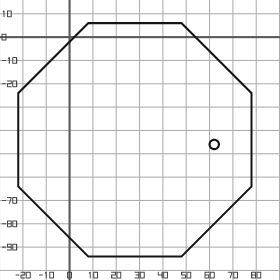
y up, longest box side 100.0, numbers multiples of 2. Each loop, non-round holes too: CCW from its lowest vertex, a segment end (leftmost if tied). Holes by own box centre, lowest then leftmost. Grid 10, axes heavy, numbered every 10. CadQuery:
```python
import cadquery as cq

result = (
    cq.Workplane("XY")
    .moveTo(8.0, -94.0)
    .lineTo(48.0, -94.0)
    .lineTo(78.0, -64.0)
    .lineTo(78.0, -24.0)
    .lineTo(48.0, 6.0)
    .lineTo(8.0, 6.0)
    .lineTo(-22.0, -24.0)
    .lineTo(-22.0, -64.0)
    .close()
    .moveTo(62.0, -46.0)
    .circle(2.0)
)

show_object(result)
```